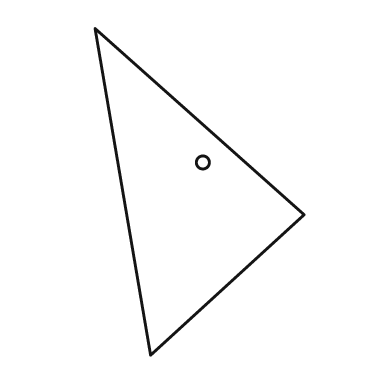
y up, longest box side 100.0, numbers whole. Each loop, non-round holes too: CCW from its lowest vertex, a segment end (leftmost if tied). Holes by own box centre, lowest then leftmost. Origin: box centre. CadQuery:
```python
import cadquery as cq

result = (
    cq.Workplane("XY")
    .moveTo(-15.0, -50.0)
    .lineTo(32.0, -7.0)
    .lineTo(-32.0, 50.0)
    .close()
    .moveTo(1.0, 9.0)
    .circle(2.0)
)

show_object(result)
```